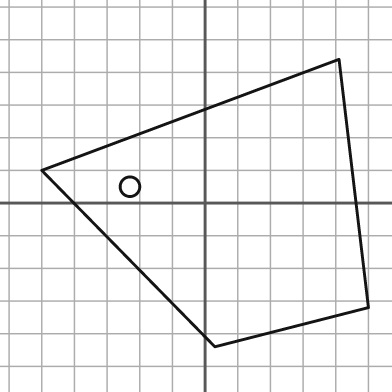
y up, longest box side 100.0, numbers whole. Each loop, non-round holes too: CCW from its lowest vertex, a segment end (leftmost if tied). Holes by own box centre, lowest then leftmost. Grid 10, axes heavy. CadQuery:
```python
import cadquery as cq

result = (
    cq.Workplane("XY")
    .moveTo(3.0, -44.0)
    .lineTo(50.0, -32.0)
    .lineTo(41.0, 44.0)
    .lineTo(-50.0, 10.0)
    .close()
    .moveTo(-23.0, 5.0)
    .circle(3.0)
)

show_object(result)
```